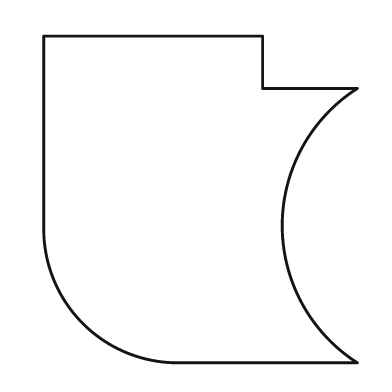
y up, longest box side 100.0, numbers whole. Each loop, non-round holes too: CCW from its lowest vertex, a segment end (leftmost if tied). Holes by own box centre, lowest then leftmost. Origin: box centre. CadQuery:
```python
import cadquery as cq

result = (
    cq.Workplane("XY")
    .moveTo(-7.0, -50.0)
    .lineTo(48.0, -50.0)
    .threePointArc((25.0, -8.0), (48.0, 34.0))
    .lineTo(19.0, 34.0)
    .lineTo(19.0, 50.0)
    .lineTo(-48.0, 50.0)
    .lineTo(-48.0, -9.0)
    .threePointArc((-36.0, -38.0), (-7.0, -50.0))
    .close()
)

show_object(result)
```